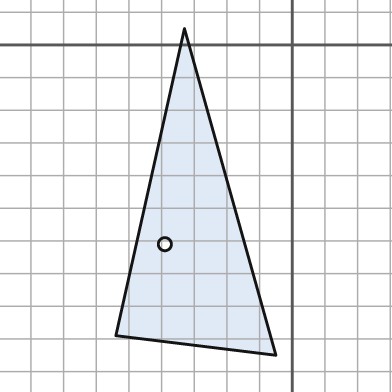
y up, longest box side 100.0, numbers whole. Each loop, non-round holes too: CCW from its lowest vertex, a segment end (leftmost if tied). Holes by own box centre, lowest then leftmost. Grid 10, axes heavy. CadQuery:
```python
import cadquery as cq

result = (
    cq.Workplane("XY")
    .moveTo(-5.0, -95.0)
    .lineTo(-33.0, 5.0)
    .lineTo(-54.0, -89.0)
    .close()
    .moveTo(-39.0, -61.0)
    .circle(2.0)
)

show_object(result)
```